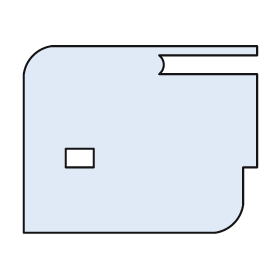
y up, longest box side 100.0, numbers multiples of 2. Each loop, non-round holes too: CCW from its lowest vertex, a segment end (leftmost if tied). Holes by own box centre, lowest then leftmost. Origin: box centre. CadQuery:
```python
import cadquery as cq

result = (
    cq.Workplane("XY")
    .moveTo(-50.0, -40.0)
    .lineTo(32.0, -40.0)
    .threePointArc((40.0, -36.0), (44.0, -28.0))
    .lineTo(44.0, -12.0)
    .lineTo(50.0, -12.0)
    .lineTo(50.0, 28.0)
    .lineTo(8.0, 28.0)
    .threePointArc((10.0, 32.0), (8.0, 36.0))
    .lineTo(50.0, 36.0)
    .lineTo(50.0, 40.0)
    .lineTo(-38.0, 40.0)
    .threePointArc((-46.0, 36.0), (-50.0, 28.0))
    .close()
    .moveTo(-32.0, -12.0)
    .lineTo(-20.0, -12.0)
    .lineTo(-20.0, -4.0)
    .lineTo(-32.0, -4.0)
    .close()
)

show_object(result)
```